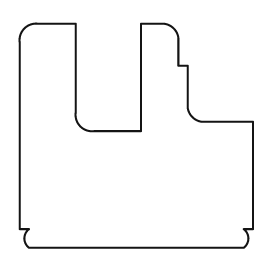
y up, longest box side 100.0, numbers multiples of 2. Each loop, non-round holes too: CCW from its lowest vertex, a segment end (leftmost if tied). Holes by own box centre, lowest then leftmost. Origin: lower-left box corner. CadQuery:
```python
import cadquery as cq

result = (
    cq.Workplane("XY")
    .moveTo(4.0, 0.0)
    .lineTo(96.0, 0.0)
    .threePointArc((98.0, 4.0), (96.0, 8.0))
    .lineTo(100.0, 8.0)
    .lineTo(100.0, 54.0)
    .lineTo(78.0, 54.0)
    .threePointArc((74.0, 56.0), (72.0, 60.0))
    .lineTo(72.0, 78.0)
    .lineTo(68.0, 78.0)
    .lineTo(68.0, 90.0)
    .threePointArc((66.0, 94.0), (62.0, 96.0))
    .lineTo(52.0, 96.0)
    .lineTo(52.0, 50.0)
    .lineTo(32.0, 50.0)
    .threePointArc((26.0, 52.0), (24.0, 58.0))
    .lineTo(24.0, 96.0)
    .lineTo(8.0, 96.0)
    .threePointArc((2.0, 94.0), (0.0, 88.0))
    .lineTo(0.0, 8.0)
    .lineTo(4.0, 8.0)
    .threePointArc((2.0, 4.0), (4.0, 0.0))
    .close()
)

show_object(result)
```